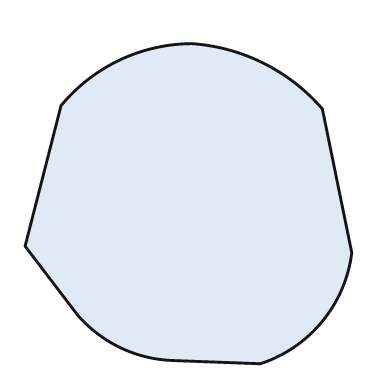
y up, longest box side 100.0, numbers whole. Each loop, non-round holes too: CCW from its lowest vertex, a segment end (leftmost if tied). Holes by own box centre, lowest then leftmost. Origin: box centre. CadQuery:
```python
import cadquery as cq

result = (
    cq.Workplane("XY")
    .moveTo(22.0, -49.0)
    .threePointArc((41.0, -36.0), (50.0, -15.0))
    .lineTo(41.0, 29.0)
    .threePointArc((23.0, 43.0), (1.0, 49.0))
    .threePointArc((-21.0, 44.0), (-39.0, 30.0))
    .lineTo(-50.0, -13.0)
    .lineTo(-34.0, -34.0)
    .threePointArc((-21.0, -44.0), (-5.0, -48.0))
    .close()
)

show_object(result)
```